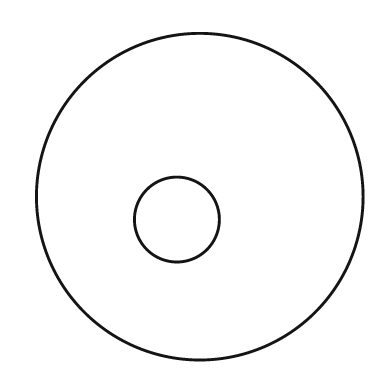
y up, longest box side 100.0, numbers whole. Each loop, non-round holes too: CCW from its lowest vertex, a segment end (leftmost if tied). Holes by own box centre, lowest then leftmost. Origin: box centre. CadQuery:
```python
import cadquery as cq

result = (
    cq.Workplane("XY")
    .moveTo(0.0, 0.0)
    .circle(50.0)
    .moveTo(-7.0, -7.0)
    .circle(13.0)
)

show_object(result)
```